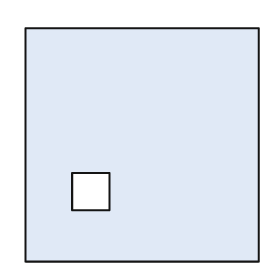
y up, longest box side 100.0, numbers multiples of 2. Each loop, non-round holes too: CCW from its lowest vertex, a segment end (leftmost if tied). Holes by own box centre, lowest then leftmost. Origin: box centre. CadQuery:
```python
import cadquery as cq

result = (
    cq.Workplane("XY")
    .moveTo(-50.0, -50.0)
    .lineTo(50.0, -50.0)
    .lineTo(50.0, 50.0)
    .lineTo(-50.0, 50.0)
    .close()
    .moveTo(-30.0, -28.0)
    .lineTo(-14.0, -28.0)
    .lineTo(-14.0, -12.0)
    .lineTo(-30.0, -12.0)
    .close()
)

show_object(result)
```